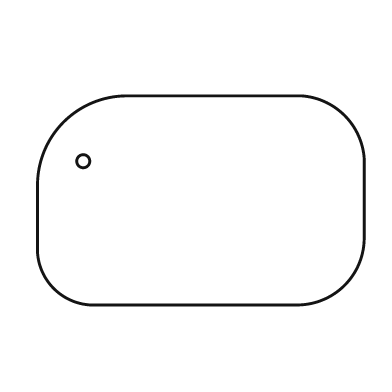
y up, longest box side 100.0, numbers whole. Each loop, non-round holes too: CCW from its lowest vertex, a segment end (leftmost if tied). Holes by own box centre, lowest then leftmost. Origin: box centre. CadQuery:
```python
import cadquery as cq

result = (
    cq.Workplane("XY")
    .moveTo(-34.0, -32.0)
    .lineTo(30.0, -32.0)
    .threePointArc((44.0, -26.0), (50.0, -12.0))
    .lineTo(50.0, 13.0)
    .threePointArc((44.0, 26.0), (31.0, 32.0))
    .lineTo(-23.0, 32.0)
    .threePointArc((-42.0, 24.0), (-50.0, 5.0))
    .lineTo(-50.0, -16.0)
    .threePointArc((-45.0, -27.0), (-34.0, -32.0))
    .close()
    .moveTo(-36.0, 12.0)
    .circle(2.0)
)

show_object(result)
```